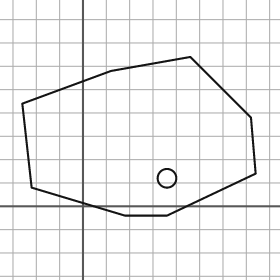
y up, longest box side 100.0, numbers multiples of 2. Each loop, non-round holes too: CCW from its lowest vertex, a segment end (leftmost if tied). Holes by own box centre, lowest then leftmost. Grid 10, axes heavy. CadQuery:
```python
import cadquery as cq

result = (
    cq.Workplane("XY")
    .moveTo(18.0, -4.0)
    .lineTo(36.0, -4.0)
    .lineTo(74.0, 14.0)
    .lineTo(72.0, 38.0)
    .lineTo(46.0, 64.0)
    .lineTo(12.0, 58.0)
    .lineTo(-26.0, 44.0)
    .lineTo(-22.0, 8.0)
    .close()
    .moveTo(36.0, 12.0)
    .circle(4.0)
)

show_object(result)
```